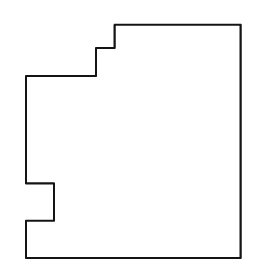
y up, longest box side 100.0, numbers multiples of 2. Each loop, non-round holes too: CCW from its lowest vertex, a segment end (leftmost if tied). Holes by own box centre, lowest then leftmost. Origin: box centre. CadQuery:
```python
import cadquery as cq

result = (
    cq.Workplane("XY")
    .moveTo(-46.0, -50.0)
    .lineTo(46.0, -50.0)
    .lineTo(46.0, 50.0)
    .lineTo(-8.0, 50.0)
    .lineTo(-8.0, 40.0)
    .lineTo(-16.0, 40.0)
    .lineTo(-16.0, 28.0)
    .lineTo(-46.0, 28.0)
    .lineTo(-46.0, -18.0)
    .lineTo(-34.0, -18.0)
    .lineTo(-34.0, -34.0)
    .lineTo(-46.0, -34.0)
    .close()
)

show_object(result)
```